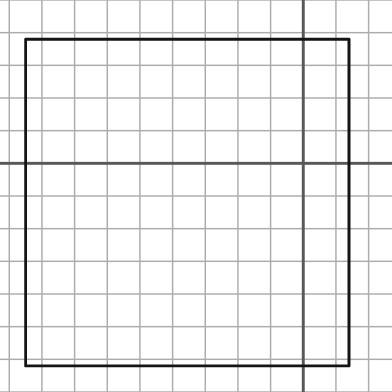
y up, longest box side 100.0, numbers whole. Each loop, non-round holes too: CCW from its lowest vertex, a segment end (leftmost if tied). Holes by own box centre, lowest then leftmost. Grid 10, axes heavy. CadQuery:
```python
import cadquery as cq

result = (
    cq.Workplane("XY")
    .moveTo(-85.0, -62.0)
    .lineTo(14.0, -62.0)
    .lineTo(14.0, 38.0)
    .lineTo(-85.0, 38.0)
    .close()
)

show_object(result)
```